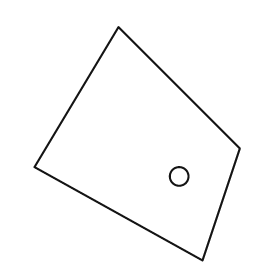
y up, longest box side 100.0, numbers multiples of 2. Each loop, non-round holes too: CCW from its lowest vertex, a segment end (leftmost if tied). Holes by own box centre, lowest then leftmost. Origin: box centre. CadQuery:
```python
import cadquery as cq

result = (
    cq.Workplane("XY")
    .moveTo(28.0, -50.0)
    .lineTo(44.0, -2.0)
    .lineTo(-8.0, 50.0)
    .lineTo(-44.0, -10.0)
    .close()
    .moveTo(18.0, -14.0)
    .circle(4.0)
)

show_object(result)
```